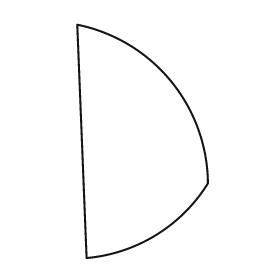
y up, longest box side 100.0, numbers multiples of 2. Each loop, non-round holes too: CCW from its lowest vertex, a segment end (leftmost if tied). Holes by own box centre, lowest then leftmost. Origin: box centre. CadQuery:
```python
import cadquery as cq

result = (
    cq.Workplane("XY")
    .moveTo(-24.0, -50.0)
    .threePointArc((6.0, -40.0), (28.0, -18.0))
    .threePointArc((12.0, 26.0), (-28.0, 50.0))
    .close()
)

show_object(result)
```